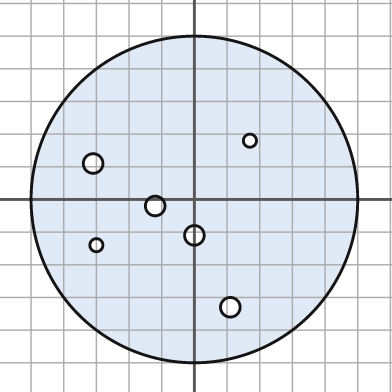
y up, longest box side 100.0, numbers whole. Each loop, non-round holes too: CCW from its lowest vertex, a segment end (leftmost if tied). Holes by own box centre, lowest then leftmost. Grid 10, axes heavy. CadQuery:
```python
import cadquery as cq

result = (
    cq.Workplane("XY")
    .moveTo(0.0, 0.0)
    .circle(50.0)
    .moveTo(11.0, -33.0)
    .circle(3.0)
    .moveTo(-30.0, -14.0)
    .circle(2.0)
    .moveTo(0.0, -11.0)
    .circle(3.0)
    .moveTo(-12.0, -2.0)
    .circle(3.0)
    .moveTo(-31.0, 11.0)
    .circle(3.0)
    .moveTo(17.0, 18.0)
    .circle(2.0)
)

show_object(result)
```